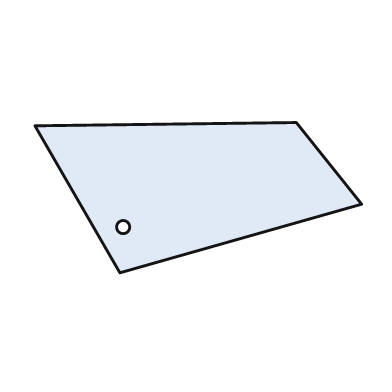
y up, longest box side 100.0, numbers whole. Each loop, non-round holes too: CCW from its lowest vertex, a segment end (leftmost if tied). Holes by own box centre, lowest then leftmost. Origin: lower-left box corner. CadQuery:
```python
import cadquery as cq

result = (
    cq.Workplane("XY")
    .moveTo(26.0, 0.0)
    .lineTo(100.0, 21.0)
    .lineTo(80.0, 46.0)
    .lineTo(0.0, 45.0)
    .close()
    .moveTo(27.0, 14.0)
    .circle(2.0)
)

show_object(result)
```